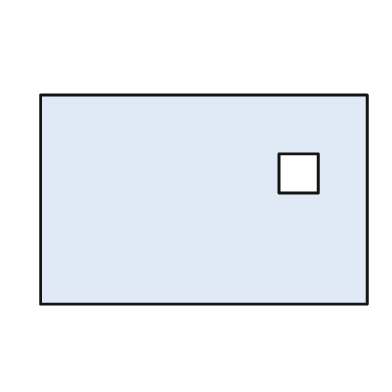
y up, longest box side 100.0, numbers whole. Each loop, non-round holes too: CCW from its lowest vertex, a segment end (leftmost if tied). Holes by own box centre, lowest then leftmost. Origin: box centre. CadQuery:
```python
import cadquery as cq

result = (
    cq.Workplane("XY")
    .moveTo(-50.0, -32.0)
    .lineTo(50.0, -32.0)
    .lineTo(50.0, 32.0)
    .lineTo(-50.0, 32.0)
    .close()
    .moveTo(23.0, 2.0)
    .lineTo(35.0, 2.0)
    .lineTo(35.0, 14.0)
    .lineTo(23.0, 14.0)
    .close()
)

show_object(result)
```